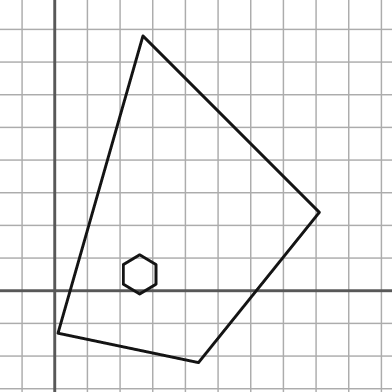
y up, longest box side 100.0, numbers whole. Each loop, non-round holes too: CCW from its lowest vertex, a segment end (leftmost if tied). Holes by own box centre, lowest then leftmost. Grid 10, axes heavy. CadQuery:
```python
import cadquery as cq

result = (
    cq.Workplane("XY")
    .moveTo(44.0, -22.0)
    .lineTo(81.0, 24.0)
    .lineTo(27.0, 78.0)
    .lineTo(1.0, -13.0)
    .close()
    .moveTo(26.0, -1.0)
    .lineTo(31.0, 2.0)
    .lineTo(31.0, 8.0)
    .lineTo(26.0, 11.0)
    .lineTo(21.0, 8.0)
    .lineTo(21.0, 2.0)
    .close()
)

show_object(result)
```